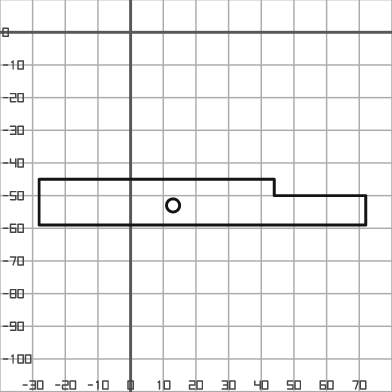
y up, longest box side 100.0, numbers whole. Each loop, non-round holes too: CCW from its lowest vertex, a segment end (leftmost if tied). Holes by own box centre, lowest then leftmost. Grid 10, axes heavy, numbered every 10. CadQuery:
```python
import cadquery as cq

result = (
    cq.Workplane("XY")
    .moveTo(-28.0, -59.0)
    .lineTo(72.0, -59.0)
    .lineTo(72.0, -50.0)
    .lineTo(44.0, -50.0)
    .lineTo(44.0, -45.0)
    .lineTo(-28.0, -45.0)
    .close()
    .moveTo(13.0, -53.0)
    .circle(2.0)
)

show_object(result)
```